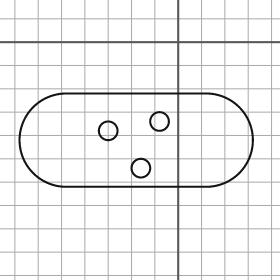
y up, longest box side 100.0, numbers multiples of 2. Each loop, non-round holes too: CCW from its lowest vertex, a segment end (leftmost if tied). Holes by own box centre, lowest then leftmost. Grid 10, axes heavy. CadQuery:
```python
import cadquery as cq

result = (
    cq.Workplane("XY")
    .moveTo(-48.0, -62.0)
    .lineTo(12.0, -62.0)
    .threePointArc((32.0, -42.0), (12.0, -22.0))
    .lineTo(-48.0, -22.0)
    .threePointArc((-68.0, -42.0), (-48.0, -62.0))
    .close()
    .moveTo(-16.0, -54.0)
    .circle(4.0)
    .moveTo(-30.0, -38.0)
    .circle(4.0)
    .moveTo(-8.0, -34.0)
    .circle(4.0)
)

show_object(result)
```